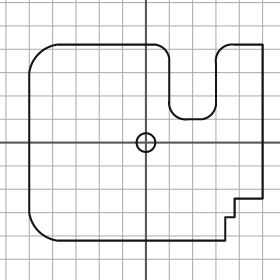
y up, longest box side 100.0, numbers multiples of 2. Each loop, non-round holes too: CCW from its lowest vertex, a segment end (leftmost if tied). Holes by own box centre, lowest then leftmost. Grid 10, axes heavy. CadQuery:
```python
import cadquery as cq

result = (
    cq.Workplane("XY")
    .moveTo(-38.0, -42.0)
    .lineTo(34.0, -42.0)
    .lineTo(34.0, -32.0)
    .lineTo(38.0, -32.0)
    .lineTo(38.0, -24.0)
    .lineTo(50.0, -24.0)
    .lineTo(50.0, 42.0)
    .lineTo(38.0, 42.0)
    .threePointArc((32.0, 40.0), (30.0, 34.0))
    .lineTo(30.0, 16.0)
    .threePointArc((28.0, 12.0), (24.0, 10.0))
    .lineTo(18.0, 10.0)
    .threePointArc((12.0, 12.0), (10.0, 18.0))
    .lineTo(10.0, 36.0)
    .threePointArc((8.0, 40.0), (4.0, 42.0))
    .lineTo(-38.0, 42.0)
    .threePointArc((-46.0, 38.0), (-50.0, 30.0))
    .lineTo(-50.0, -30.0)
    .threePointArc((-46.0, -38.0), (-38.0, -42.0))
    .close()
    .moveTo(0.0, 0.0)
    .circle(4.0)
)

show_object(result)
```